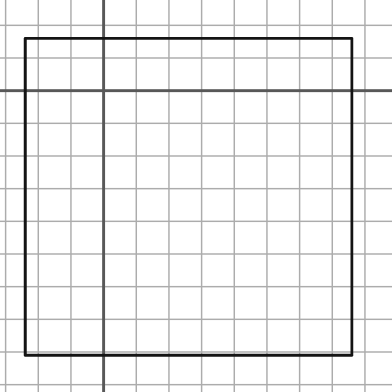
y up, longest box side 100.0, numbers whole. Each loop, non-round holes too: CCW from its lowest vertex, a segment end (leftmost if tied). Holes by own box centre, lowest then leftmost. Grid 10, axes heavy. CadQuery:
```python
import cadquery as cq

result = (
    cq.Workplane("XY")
    .moveTo(-24.0, -81.0)
    .lineTo(76.0, -81.0)
    .lineTo(76.0, 16.0)
    .lineTo(-24.0, 16.0)
    .close()
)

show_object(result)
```